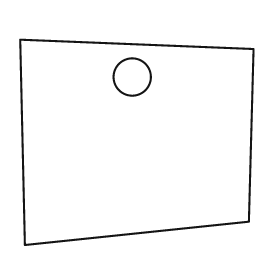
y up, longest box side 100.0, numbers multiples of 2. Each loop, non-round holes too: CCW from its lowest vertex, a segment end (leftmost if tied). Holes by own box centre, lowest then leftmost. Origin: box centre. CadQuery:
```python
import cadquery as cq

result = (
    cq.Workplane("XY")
    .moveTo(-48.0, -44.0)
    .lineTo(48.0, -34.0)
    .lineTo(50.0, 40.0)
    .lineTo(-50.0, 44.0)
    .close()
    .moveTo(-2.0, 28.0)
    .circle(8.0)
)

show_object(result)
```